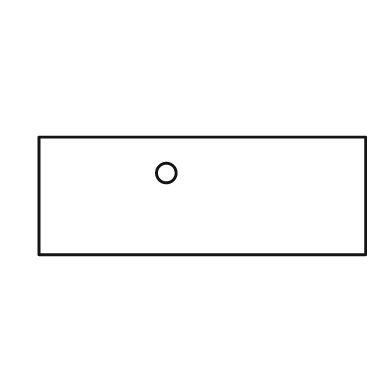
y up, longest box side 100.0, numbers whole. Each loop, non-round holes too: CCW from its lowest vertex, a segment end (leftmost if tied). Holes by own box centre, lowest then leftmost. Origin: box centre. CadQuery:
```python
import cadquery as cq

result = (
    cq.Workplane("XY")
    .moveTo(-50.0, -18.0)
    .lineTo(50.0, -18.0)
    .lineTo(50.0, 18.0)
    .lineTo(-50.0, 18.0)
    .close()
    .moveTo(-11.0, 7.0)
    .circle(3.0)
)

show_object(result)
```